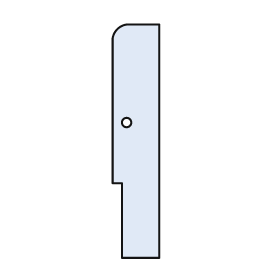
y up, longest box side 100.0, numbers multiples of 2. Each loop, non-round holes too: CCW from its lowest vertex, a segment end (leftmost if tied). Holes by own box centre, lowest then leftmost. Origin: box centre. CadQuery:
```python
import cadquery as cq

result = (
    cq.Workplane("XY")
    .moveTo(-6.0, -50.0)
    .lineTo(10.0, -50.0)
    .lineTo(10.0, 50.0)
    .lineTo(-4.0, 50.0)
    .threePointArc((-8.0, 48.0), (-10.0, 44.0))
    .lineTo(-10.0, -18.0)
    .lineTo(-6.0, -18.0)
    .close()
    .moveTo(-4.0, 8.0)
    .circle(2.0)
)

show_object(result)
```